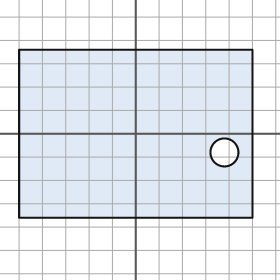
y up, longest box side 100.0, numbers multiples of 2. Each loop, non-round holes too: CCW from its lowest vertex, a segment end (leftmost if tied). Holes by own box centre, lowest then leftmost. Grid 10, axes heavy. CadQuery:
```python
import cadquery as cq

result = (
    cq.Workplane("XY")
    .moveTo(-50.0, -36.0)
    .lineTo(50.0, -36.0)
    .lineTo(50.0, 36.0)
    .lineTo(-50.0, 36.0)
    .close()
    .moveTo(38.0, -8.0)
    .circle(6.0)
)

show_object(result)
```